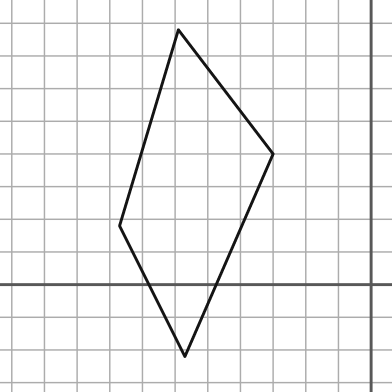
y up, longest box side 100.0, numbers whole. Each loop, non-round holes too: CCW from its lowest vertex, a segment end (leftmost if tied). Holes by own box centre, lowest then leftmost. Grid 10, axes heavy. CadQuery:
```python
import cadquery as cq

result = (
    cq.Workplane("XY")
    .moveTo(-57.0, -22.0)
    .lineTo(-30.0, 40.0)
    .lineTo(-59.0, 78.0)
    .lineTo(-77.0, 18.0)
    .close()
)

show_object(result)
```